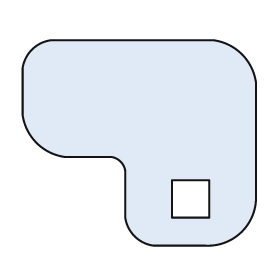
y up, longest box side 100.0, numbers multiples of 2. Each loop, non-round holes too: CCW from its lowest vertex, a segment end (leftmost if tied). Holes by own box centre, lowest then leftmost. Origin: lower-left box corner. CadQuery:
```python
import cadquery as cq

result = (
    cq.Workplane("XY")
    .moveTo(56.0, 0.0)
    .lineTo(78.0, 0.0)
    .threePointArc((94.0, 6.0), (100.0, 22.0))
    .lineTo(100.0, 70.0)
    .threePointArc((94.0, 82.0), (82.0, 88.0))
    .lineTo(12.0, 88.0)
    .threePointArc((4.0, 84.0), (0.0, 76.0))
    .lineTo(0.0, 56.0)
    .threePointArc((6.0, 44.0), (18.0, 38.0))
    .lineTo(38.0, 38.0)
    .threePointArc((42.0, 36.0), (44.0, 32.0))
    .lineTo(44.0, 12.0)
    .threePointArc((48.0, 4.0), (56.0, 0.0))
    .close()
    .moveTo(64.0, 12.0)
    .lineTo(80.0, 12.0)
    .lineTo(80.0, 28.0)
    .lineTo(64.0, 28.0)
    .close()
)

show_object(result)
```